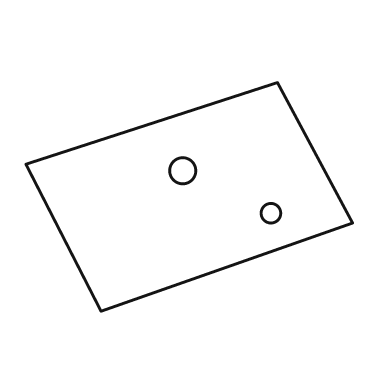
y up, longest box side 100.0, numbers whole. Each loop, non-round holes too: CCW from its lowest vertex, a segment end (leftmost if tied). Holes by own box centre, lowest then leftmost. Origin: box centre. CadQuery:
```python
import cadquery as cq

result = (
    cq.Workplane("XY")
    .moveTo(-27.0, -35.0)
    .lineTo(50.0, -8.0)
    .lineTo(27.0, 35.0)
    .lineTo(-50.0, 10.0)
    .close()
    .moveTo(25.0, -5.0)
    .circle(3.0)
    .moveTo(-2.0, 8.0)
    .circle(4.0)
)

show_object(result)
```